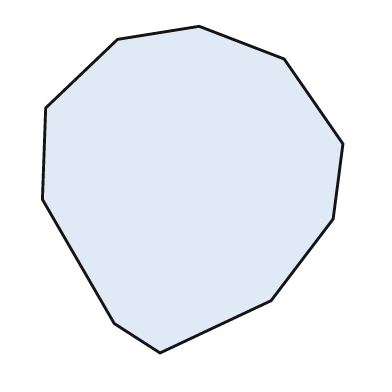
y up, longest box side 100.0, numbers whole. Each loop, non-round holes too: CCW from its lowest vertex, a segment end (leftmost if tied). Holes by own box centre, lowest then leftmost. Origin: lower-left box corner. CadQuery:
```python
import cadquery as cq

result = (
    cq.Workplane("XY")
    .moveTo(36.0, 0.0)
    .lineTo(70.0, 16.0)
    .lineTo(89.0, 41.0)
    .lineTo(92.0, 64.0)
    .lineTo(74.0, 90.0)
    .lineTo(48.0, 100.0)
    .lineTo(23.0, 96.0)
    .lineTo(1.0, 75.0)
    .lineTo(0.0, 47.0)
    .lineTo(22.0, 9.0)
    .close()
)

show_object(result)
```